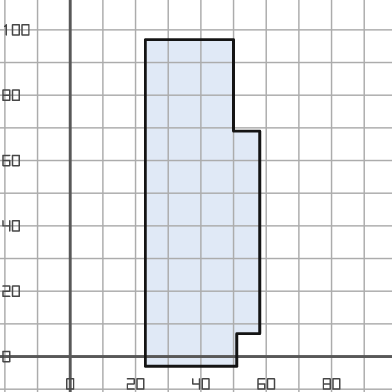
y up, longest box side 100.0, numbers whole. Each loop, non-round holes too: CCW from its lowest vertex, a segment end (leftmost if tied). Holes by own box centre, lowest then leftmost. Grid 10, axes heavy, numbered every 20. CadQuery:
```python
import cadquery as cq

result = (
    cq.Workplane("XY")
    .moveTo(23.0, -3.0)
    .lineTo(51.0, -3.0)
    .lineTo(51.0, 7.0)
    .lineTo(58.0, 7.0)
    .lineTo(58.0, 69.0)
    .lineTo(50.0, 69.0)
    .lineTo(50.0, 97.0)
    .lineTo(23.0, 97.0)
    .close()
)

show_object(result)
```